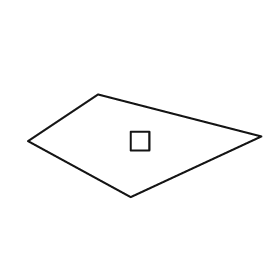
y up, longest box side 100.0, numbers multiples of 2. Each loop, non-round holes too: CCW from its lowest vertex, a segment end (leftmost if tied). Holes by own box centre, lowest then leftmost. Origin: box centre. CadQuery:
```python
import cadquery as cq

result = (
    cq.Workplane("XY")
    .moveTo(-6.0, -22.0)
    .lineTo(50.0, 4.0)
    .lineTo(-20.0, 22.0)
    .lineTo(-50.0, 2.0)
    .close()
    .moveTo(-6.0, -2.0)
    .lineTo(2.0, -2.0)
    .lineTo(2.0, 6.0)
    .lineTo(-6.0, 6.0)
    .close()
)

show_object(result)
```